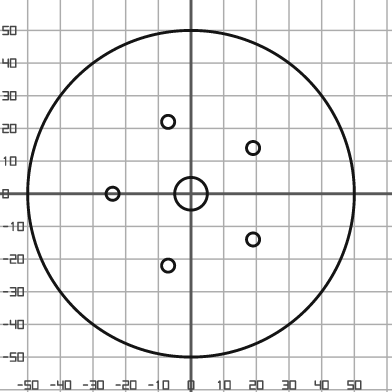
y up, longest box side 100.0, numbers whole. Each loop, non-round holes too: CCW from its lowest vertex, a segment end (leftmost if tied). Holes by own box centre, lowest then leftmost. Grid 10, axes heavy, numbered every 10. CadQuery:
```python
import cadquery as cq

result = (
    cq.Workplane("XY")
    .moveTo(0.0, 0.0)
    .circle(50.0)
    .moveTo(-7.0, -22.0)
    .circle(2.0)
    .moveTo(19.0, -14.0)
    .circle(2.0)
    .moveTo(-24.0, 0.0)
    .circle(2.0)
    .moveTo(0.0, 0.0)
    .circle(5.0)
    .moveTo(19.0, 14.0)
    .circle(2.0)
    .moveTo(-7.0, 22.0)
    .circle(2.0)
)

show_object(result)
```